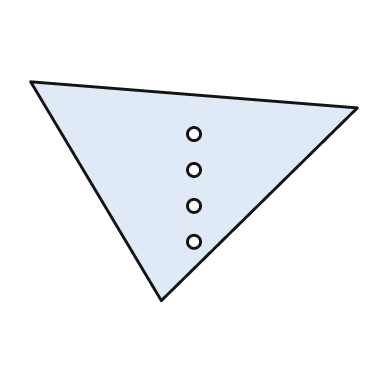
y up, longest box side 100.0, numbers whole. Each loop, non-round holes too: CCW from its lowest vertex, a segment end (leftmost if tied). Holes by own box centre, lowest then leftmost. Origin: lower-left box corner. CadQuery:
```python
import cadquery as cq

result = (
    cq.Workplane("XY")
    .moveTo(40.0, 0.0)
    .lineTo(100.0, 59.0)
    .lineTo(0.0, 67.0)
    .close()
    .moveTo(50.0, 18.0)
    .circle(2.0)
    .moveTo(50.0, 29.0)
    .circle(2.0)
    .moveTo(50.0, 40.0)
    .circle(2.0)
    .moveTo(50.0, 51.0)
    .circle(2.0)
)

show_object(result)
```